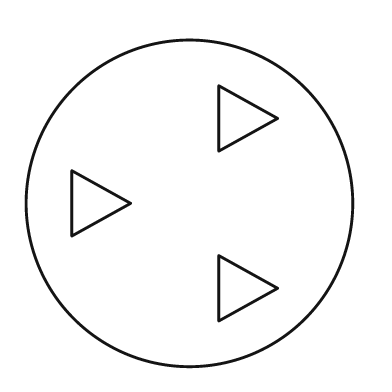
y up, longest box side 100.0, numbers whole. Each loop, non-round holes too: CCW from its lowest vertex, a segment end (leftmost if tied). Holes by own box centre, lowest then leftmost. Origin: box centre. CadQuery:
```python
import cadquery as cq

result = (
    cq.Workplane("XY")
    .moveTo(0.0, 0.0)
    .circle(50.0)
    .moveTo(9.0, -36.0)
    .lineTo(27.0, -26.0)
    .lineTo(9.0, -16.0)
    .close()
    .moveTo(-36.0, -10.0)
    .lineTo(-18.0, 0.0)
    .lineTo(-36.0, 10.0)
    .close()
    .moveTo(9.0, 16.0)
    .lineTo(27.0, 26.0)
    .lineTo(9.0, 36.0)
    .close()
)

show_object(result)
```